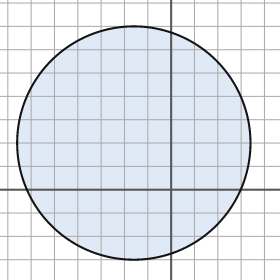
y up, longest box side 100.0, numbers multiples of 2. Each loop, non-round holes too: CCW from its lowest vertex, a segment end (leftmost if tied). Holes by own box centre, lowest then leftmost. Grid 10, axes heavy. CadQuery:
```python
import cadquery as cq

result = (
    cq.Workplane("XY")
    .moveTo(-16.0, 20.0)
    .circle(50.0)
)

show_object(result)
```